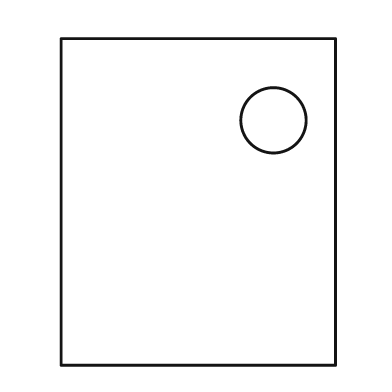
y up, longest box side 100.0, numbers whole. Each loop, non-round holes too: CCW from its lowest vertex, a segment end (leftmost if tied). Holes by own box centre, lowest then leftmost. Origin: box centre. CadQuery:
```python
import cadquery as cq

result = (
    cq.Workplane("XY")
    .moveTo(-42.0, -50.0)
    .lineTo(42.0, -50.0)
    .lineTo(42.0, 50.0)
    .lineTo(-42.0, 50.0)
    .close()
    .moveTo(23.0, 25.0)
    .circle(10.0)
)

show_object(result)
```